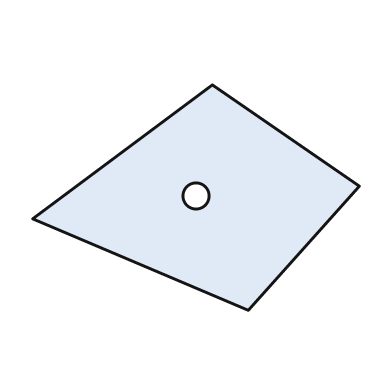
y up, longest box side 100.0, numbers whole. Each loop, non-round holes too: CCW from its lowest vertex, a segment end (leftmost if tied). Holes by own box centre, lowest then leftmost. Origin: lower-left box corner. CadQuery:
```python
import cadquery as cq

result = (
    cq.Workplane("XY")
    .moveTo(66.0, 0.0)
    .lineTo(100.0, 38.0)
    .lineTo(55.0, 69.0)
    .lineTo(0.0, 28.0)
    .close()
    .moveTo(50.0, 35.0)
    .circle(4.0)
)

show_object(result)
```